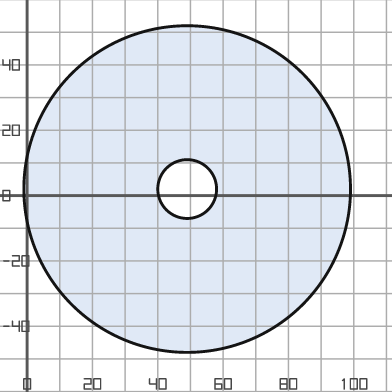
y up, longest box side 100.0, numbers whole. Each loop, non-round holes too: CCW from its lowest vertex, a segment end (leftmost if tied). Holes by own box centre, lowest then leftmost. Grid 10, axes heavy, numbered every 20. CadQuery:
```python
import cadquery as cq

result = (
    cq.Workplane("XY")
    .moveTo(49.0, 2.0)
    .circle(50.0)
    .moveTo(49.0, 2.0)
    .circle(9.0)
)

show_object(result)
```